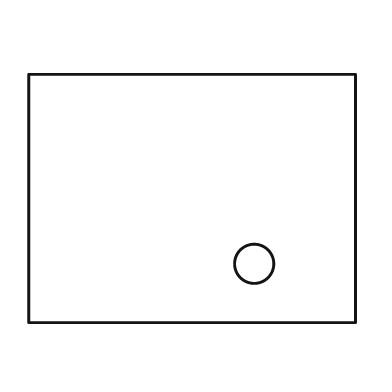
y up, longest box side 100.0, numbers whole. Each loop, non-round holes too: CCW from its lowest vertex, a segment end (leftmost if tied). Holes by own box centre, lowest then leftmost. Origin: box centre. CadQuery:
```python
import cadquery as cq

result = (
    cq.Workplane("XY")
    .moveTo(-50.0, -38.0)
    .lineTo(50.0, -38.0)
    .lineTo(50.0, 38.0)
    .lineTo(-50.0, 38.0)
    .close()
    .moveTo(19.0, -20.0)
    .circle(6.0)
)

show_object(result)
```